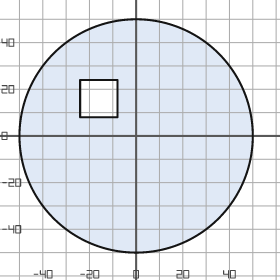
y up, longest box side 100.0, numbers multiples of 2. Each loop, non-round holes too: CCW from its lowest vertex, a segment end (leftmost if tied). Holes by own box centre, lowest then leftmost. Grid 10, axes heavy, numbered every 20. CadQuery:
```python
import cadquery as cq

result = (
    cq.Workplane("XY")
    .moveTo(0.0, 0.0)
    .circle(50.0)
    .moveTo(-24.0, 8.0)
    .lineTo(-8.0, 8.0)
    .lineTo(-8.0, 24.0)
    .lineTo(-24.0, 24.0)
    .close()
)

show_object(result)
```